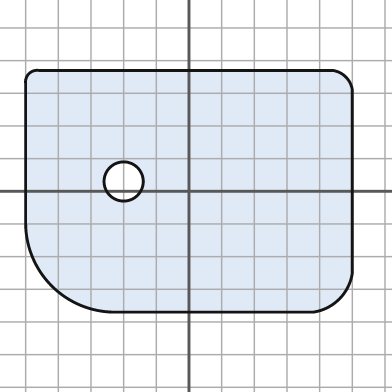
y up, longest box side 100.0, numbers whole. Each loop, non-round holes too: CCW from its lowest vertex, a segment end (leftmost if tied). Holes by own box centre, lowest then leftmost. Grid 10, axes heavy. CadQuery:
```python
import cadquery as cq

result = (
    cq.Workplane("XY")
    .moveTo(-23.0, -37.0)
    .lineTo(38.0, -37.0)
    .threePointArc((46.0, -33.0), (50.0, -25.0))
    .lineTo(50.0, 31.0)
    .threePointArc((48.0, 35.0), (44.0, 37.0))
    .lineTo(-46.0, 37.0)
    .threePointArc((-49.0, 36.0), (-50.0, 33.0))
    .lineTo(-50.0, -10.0)
    .threePointArc((-42.0, -29.0), (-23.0, -37.0))
    .close()
    .moveTo(-20.0, 3.0)
    .circle(6.0)
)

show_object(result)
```